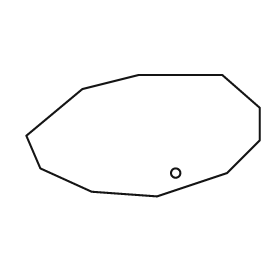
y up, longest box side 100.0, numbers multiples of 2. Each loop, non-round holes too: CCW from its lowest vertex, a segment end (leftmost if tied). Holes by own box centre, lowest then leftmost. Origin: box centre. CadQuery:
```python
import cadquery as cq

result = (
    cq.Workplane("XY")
    .moveTo(6.0, -26.0)
    .lineTo(36.0, -16.0)
    .lineTo(50.0, -2.0)
    .lineTo(50.0, 12.0)
    .lineTo(34.0, 26.0)
    .lineTo(-2.0, 26.0)
    .lineTo(-26.0, 20.0)
    .lineTo(-50.0, 0.0)
    .lineTo(-44.0, -14.0)
    .lineTo(-22.0, -24.0)
    .close()
    .moveTo(14.0, -16.0)
    .circle(2.0)
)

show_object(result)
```